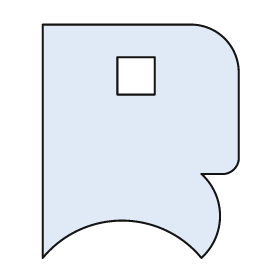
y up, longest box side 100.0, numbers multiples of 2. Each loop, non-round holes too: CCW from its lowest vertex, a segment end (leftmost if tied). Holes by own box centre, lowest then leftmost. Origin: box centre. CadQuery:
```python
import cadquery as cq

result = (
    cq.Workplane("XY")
    .moveTo(-42.0, -50.0)
    .threePointArc((-8.0, -34.0), (26.0, -50.0))
    .threePointArc((34.0, -32.0), (26.0, -14.0))
    .lineTo(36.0, -14.0)
    .threePointArc((40.0, -12.0), (42.0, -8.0))
    .lineTo(42.0, 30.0)
    .threePointArc((36.0, 44.0), (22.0, 50.0))
    .lineTo(-42.0, 50.0)
    .close()
    .moveTo(-10.0, 20.0)
    .lineTo(6.0, 20.0)
    .lineTo(6.0, 36.0)
    .lineTo(-10.0, 36.0)
    .close()
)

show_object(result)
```